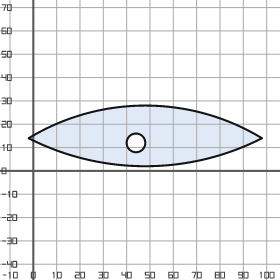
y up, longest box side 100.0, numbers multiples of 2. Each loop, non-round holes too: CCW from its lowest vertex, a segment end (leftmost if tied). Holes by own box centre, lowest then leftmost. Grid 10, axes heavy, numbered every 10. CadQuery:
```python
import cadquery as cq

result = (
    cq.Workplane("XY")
    .moveTo(-2.0, 14.0)
    .threePointArc((48.0, 2.0), (98.0, 14.0))
    .threePointArc((48.0, 28.0), (-2.0, 14.0))
    .close()
    .moveTo(44.0, 12.0)
    .circle(4.0)
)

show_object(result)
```